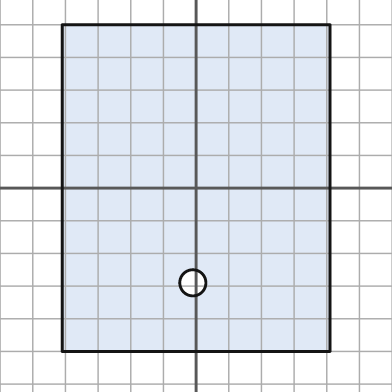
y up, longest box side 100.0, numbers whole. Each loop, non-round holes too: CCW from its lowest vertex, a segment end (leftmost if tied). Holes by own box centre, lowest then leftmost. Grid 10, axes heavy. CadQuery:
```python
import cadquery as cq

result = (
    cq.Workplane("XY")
    .moveTo(-41.0, -50.0)
    .lineTo(41.0, -50.0)
    .lineTo(41.0, 50.0)
    .lineTo(-41.0, 50.0)
    .close()
    .moveTo(-1.0, -29.0)
    .circle(4.0)
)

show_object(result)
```